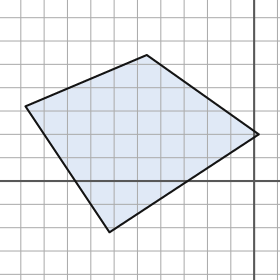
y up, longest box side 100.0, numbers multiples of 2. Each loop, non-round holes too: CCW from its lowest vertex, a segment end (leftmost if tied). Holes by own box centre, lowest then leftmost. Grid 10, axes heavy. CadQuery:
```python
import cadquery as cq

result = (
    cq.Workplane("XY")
    .moveTo(-62.0, -22.0)
    .lineTo(2.0, 20.0)
    .lineTo(-46.0, 54.0)
    .lineTo(-98.0, 32.0)
    .close()
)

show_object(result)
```